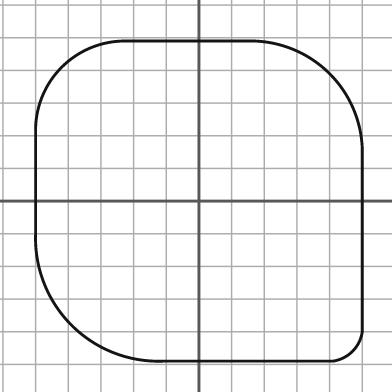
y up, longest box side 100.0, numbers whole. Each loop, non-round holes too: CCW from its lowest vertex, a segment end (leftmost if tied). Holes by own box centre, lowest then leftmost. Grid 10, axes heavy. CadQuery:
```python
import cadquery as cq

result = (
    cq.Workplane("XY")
    .moveTo(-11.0, -49.0)
    .lineTo(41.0, -49.0)
    .threePointArc((47.0, -46.0), (50.0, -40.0))
    .lineTo(50.0, 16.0)
    .threePointArc((40.0, 39.0), (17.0, 49.0))
    .lineTo(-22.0, 49.0)
    .threePointArc((-42.0, 41.0), (-50.0, 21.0))
    .lineTo(-50.0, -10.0)
    .threePointArc((-39.0, -38.0), (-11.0, -49.0))
    .close()
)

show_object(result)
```